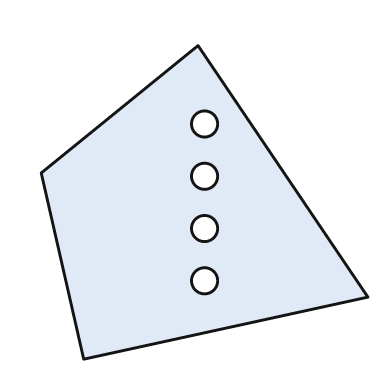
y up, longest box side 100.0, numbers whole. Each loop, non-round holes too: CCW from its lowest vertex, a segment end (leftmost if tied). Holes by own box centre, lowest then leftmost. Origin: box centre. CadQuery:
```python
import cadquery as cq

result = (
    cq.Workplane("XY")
    .moveTo(-37.0, -48.0)
    .lineTo(50.0, -29.0)
    .lineTo(-2.0, 48.0)
    .lineTo(-50.0, 9.0)
    .close()
    .moveTo(0.0, -24.0)
    .circle(4.0)
    .moveTo(0.0, -8.0)
    .circle(4.0)
    .moveTo(0.0, 8.0)
    .circle(4.0)
    .moveTo(0.0, 24.0)
    .circle(4.0)
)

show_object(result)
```